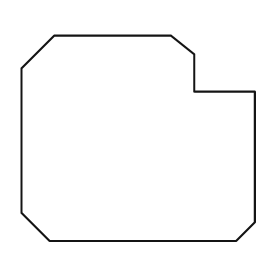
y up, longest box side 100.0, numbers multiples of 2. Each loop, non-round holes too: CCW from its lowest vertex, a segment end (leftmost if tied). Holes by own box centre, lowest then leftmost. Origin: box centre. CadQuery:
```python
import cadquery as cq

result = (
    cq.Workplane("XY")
    .moveTo(-38.0, -44.0)
    .lineTo(42.0, -44.0)
    .lineTo(50.0, -36.0)
    .lineTo(50.0, 20.0)
    .lineTo(24.0, 20.0)
    .lineTo(24.0, 36.0)
    .lineTo(14.0, 44.0)
    .lineTo(-36.0, 44.0)
    .lineTo(-50.0, 30.0)
    .lineTo(-50.0, -32.0)
    .close()
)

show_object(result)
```